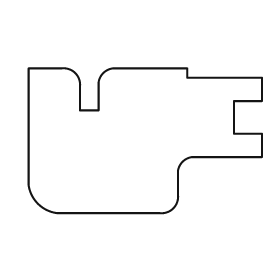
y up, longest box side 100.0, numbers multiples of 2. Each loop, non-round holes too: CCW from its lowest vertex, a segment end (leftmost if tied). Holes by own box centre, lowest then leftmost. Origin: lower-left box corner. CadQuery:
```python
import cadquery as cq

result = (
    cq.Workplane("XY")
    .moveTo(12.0, 0.0)
    .lineTo(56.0, 0.0)
    .threePointArc((62.0, 2.0), (64.0, 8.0))
    .lineTo(64.0, 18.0)
    .threePointArc((66.0, 22.0), (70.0, 24.0))
    .lineTo(100.0, 24.0)
    .lineTo(100.0, 34.0)
    .lineTo(88.0, 34.0)
    .lineTo(88.0, 48.0)
    .lineTo(100.0, 48.0)
    .lineTo(100.0, 58.0)
    .lineTo(68.0, 58.0)
    .lineTo(68.0, 62.0)
    .lineTo(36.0, 62.0)
    .threePointArc((32.0, 60.0), (30.0, 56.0))
    .lineTo(30.0, 44.0)
    .lineTo(22.0, 44.0)
    .lineTo(22.0, 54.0)
    .threePointArc((20.0, 60.0), (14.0, 62.0))
    .lineTo(0.0, 62.0)
    .lineTo(0.0, 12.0)
    .threePointArc((4.0, 4.0), (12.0, 0.0))
    .close()
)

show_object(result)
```